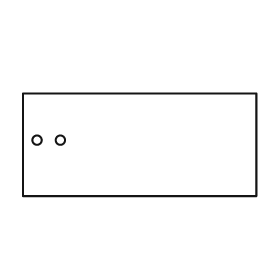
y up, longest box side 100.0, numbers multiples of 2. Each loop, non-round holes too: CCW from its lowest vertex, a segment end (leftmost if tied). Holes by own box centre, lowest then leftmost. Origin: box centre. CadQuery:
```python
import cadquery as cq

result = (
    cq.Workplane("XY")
    .moveTo(-50.0, -22.0)
    .lineTo(50.0, -22.0)
    .lineTo(50.0, 22.0)
    .lineTo(-50.0, 22.0)
    .close()
    .moveTo(-44.0, 2.0)
    .circle(2.0)
    .moveTo(-34.0, 2.0)
    .circle(2.0)
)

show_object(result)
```